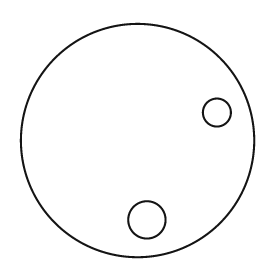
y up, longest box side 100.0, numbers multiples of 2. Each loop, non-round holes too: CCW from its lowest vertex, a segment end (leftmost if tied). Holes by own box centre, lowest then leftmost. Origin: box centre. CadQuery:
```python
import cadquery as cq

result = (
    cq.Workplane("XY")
    .moveTo(0.0, 0.0)
    .circle(50.0)
    .moveTo(4.0, -34.0)
    .circle(8.0)
    .moveTo(34.0, 12.0)
    .circle(6.0)
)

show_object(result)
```